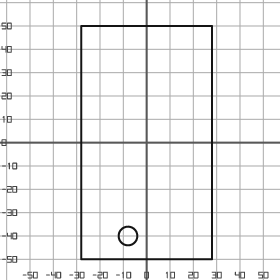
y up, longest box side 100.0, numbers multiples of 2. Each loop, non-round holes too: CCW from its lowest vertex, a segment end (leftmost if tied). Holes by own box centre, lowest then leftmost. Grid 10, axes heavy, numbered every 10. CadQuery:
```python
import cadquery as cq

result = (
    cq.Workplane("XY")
    .moveTo(-28.0, -50.0)
    .lineTo(28.0, -50.0)
    .lineTo(28.0, 50.0)
    .lineTo(-28.0, 50.0)
    .close()
    .moveTo(-8.0, -40.0)
    .circle(4.0)
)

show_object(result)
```